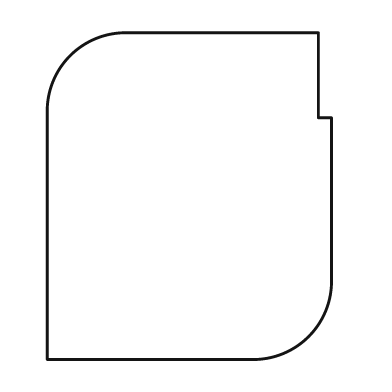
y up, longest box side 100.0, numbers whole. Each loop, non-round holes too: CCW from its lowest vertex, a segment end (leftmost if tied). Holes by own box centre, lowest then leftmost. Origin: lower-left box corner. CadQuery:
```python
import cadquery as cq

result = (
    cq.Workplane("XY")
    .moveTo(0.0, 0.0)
    .lineTo(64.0, 0.0)
    .threePointArc((80.0, 7.0), (87.0, 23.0))
    .lineTo(87.0, 74.0)
    .lineTo(83.0, 74.0)
    .lineTo(83.0, 100.0)
    .lineTo(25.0, 100.0)
    .threePointArc((7.0, 93.0), (0.0, 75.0))
    .close()
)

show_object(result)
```